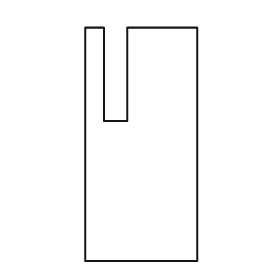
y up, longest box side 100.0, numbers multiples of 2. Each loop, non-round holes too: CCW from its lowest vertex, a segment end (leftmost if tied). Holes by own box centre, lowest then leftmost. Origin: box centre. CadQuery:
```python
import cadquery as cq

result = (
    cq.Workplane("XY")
    .moveTo(-24.0, -50.0)
    .lineTo(24.0, -50.0)
    .lineTo(24.0, 50.0)
    .lineTo(-6.0, 50.0)
    .lineTo(-6.0, 10.0)
    .lineTo(-16.0, 10.0)
    .lineTo(-16.0, 50.0)
    .lineTo(-24.0, 50.0)
    .close()
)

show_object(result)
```